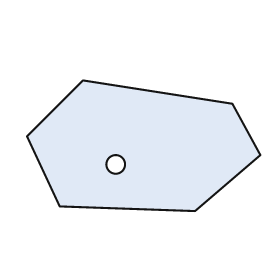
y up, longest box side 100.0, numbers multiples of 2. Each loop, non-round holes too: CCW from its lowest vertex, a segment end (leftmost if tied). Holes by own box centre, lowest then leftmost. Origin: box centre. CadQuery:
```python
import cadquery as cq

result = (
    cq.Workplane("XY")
    .moveTo(22.0, -28.0)
    .lineTo(50.0, -4.0)
    .lineTo(38.0, 18.0)
    .lineTo(-26.0, 28.0)
    .lineTo(-50.0, 4.0)
    .lineTo(-36.0, -26.0)
    .close()
    .moveTo(-12.0, -8.0)
    .circle(4.0)
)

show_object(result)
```